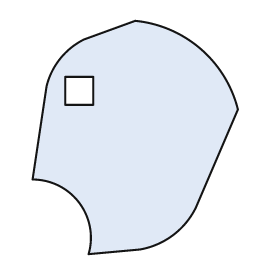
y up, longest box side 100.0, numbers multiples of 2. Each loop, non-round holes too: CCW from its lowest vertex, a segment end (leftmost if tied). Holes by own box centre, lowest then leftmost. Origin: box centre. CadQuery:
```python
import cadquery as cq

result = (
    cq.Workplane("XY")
    .moveTo(-20.0, -50.0)
    .lineTo(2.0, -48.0)
    .threePointArc((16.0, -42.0), (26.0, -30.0))
    .lineTo(44.0, 12.0)
    .threePointArc((28.0, 38.0), (0.0, 50.0))
    .lineTo(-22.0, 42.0)
    .threePointArc((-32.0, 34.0), (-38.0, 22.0))
    .lineTo(-44.0, -18.0)
    .threePointArc((-24.0, -28.0), (-20.0, -50.0))
    .close()
    .moveTo(-30.0, 14.0)
    .lineTo(-18.0, 14.0)
    .lineTo(-18.0, 26.0)
    .lineTo(-30.0, 26.0)
    .close()
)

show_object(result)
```